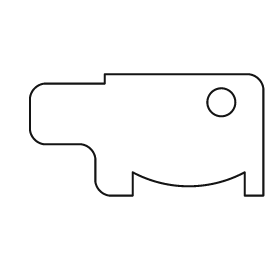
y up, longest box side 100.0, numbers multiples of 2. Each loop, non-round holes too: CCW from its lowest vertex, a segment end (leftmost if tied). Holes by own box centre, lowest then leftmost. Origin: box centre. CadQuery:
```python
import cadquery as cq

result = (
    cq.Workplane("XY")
    .moveTo(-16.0, -26.0)
    .lineTo(-6.0, -26.0)
    .lineTo(-6.0, -16.0)
    .threePointArc((18.0, -22.0), (42.0, -16.0))
    .lineTo(42.0, -26.0)
    .lineTo(50.0, -26.0)
    .lineTo(50.0, 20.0)
    .threePointArc((48.0, 24.0), (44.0, 26.0))
    .lineTo(-18.0, 26.0)
    .lineTo(-18.0, 22.0)
    .lineTo(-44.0, 22.0)
    .threePointArc((-48.0, 20.0), (-50.0, 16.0))
    .lineTo(-50.0, 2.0)
    .threePointArc((-48.0, -2.0), (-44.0, -4.0))
    .lineTo(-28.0, -4.0)
    .threePointArc((-24.0, -6.0), (-22.0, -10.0))
    .lineTo(-22.0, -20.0)
    .threePointArc((-20.0, -24.0), (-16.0, -26.0))
    .close()
    .moveTo(32.0, 14.0)
    .circle(6.0)
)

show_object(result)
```